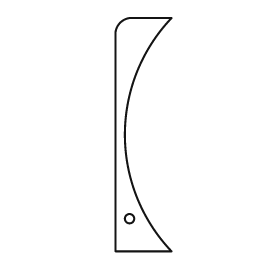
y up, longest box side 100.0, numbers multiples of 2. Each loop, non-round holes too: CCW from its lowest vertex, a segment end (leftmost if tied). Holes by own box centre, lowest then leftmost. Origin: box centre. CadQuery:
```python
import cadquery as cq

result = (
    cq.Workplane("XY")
    .moveTo(-12.0, -50.0)
    .lineTo(12.0, -50.0)
    .threePointArc((-8.0, 0.0), (12.0, 50.0))
    .lineTo(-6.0, 50.0)
    .threePointArc((-10.0, 48.0), (-12.0, 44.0))
    .close()
    .moveTo(-6.0, -36.0)
    .circle(2.0)
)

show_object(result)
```